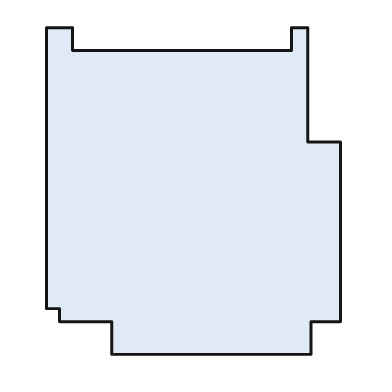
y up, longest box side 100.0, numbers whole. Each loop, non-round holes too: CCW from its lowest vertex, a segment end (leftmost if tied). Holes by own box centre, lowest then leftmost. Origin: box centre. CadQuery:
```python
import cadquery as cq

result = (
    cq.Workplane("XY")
    .moveTo(-25.0, -50.0)
    .lineTo(36.0, -50.0)
    .lineTo(36.0, -40.0)
    .lineTo(45.0, -40.0)
    .lineTo(45.0, 15.0)
    .lineTo(35.0, 15.0)
    .lineTo(35.0, 50.0)
    .lineTo(30.0, 50.0)
    .lineTo(30.0, 43.0)
    .lineTo(-37.0, 43.0)
    .lineTo(-37.0, 50.0)
    .lineTo(-45.0, 50.0)
    .lineTo(-45.0, -36.0)
    .lineTo(-41.0, -36.0)
    .lineTo(-41.0, -40.0)
    .lineTo(-25.0, -40.0)
    .close()
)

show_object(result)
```